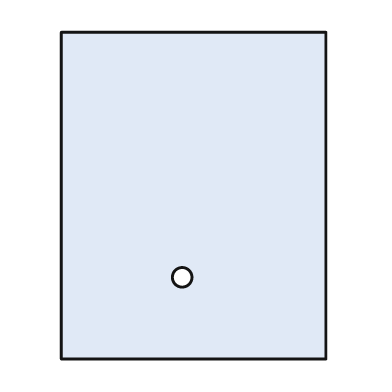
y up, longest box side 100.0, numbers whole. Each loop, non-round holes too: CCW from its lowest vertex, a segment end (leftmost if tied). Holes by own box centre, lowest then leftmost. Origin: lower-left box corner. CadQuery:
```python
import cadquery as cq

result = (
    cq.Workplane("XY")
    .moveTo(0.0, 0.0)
    .lineTo(81.0, 0.0)
    .lineTo(81.0, 100.0)
    .lineTo(0.0, 100.0)
    .close()
    .moveTo(37.0, 25.0)
    .circle(3.0)
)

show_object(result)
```